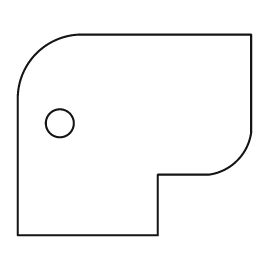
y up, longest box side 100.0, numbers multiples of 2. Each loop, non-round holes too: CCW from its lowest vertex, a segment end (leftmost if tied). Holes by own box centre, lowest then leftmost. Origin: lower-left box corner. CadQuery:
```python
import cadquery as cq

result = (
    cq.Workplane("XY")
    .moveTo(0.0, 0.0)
    .lineTo(60.0, 0.0)
    .lineTo(60.0, 26.0)
    .lineTo(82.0, 26.0)
    .threePointArc((94.0, 32.0), (100.0, 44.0))
    .lineTo(100.0, 86.0)
    .lineTo(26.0, 86.0)
    .threePointArc((8.0, 78.0), (0.0, 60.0))
    .close()
    .moveTo(18.0, 48.0)
    .circle(6.0)
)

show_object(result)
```